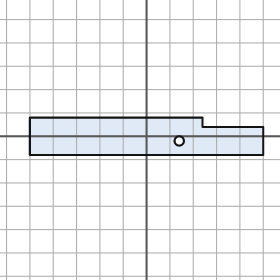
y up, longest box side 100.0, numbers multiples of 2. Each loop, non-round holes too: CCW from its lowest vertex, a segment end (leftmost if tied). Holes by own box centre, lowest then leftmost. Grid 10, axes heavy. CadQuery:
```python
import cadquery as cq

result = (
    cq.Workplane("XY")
    .moveTo(-50.0, -8.0)
    .lineTo(50.0, -8.0)
    .lineTo(50.0, 4.0)
    .lineTo(24.0, 4.0)
    .lineTo(24.0, 8.0)
    .lineTo(-50.0, 8.0)
    .close()
    .moveTo(14.0, -2.0)
    .circle(2.0)
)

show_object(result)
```